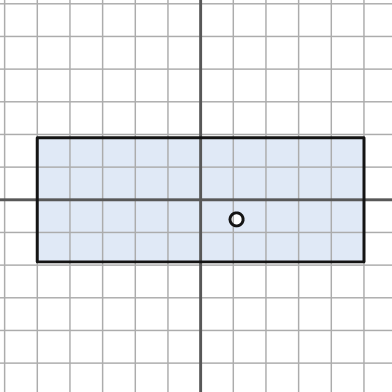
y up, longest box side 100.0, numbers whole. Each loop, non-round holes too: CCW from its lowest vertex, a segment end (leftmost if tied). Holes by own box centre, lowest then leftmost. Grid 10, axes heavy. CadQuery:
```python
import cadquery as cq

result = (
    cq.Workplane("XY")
    .moveTo(-50.0, -19.0)
    .lineTo(50.0, -19.0)
    .lineTo(50.0, 19.0)
    .lineTo(-50.0, 19.0)
    .close()
    .moveTo(11.0, -6.0)
    .circle(2.0)
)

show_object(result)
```